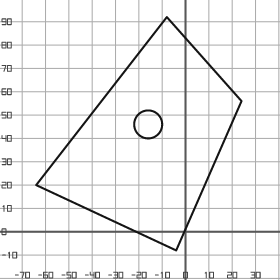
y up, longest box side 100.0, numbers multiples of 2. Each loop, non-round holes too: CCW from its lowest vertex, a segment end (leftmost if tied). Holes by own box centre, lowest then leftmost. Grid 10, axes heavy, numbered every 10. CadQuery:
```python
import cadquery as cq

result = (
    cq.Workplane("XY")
    .moveTo(-4.0, -8.0)
    .lineTo(24.0, 56.0)
    .lineTo(-8.0, 92.0)
    .lineTo(-64.0, 20.0)
    .close()
    .moveTo(-16.0, 46.0)
    .circle(6.0)
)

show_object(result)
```